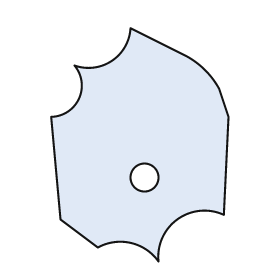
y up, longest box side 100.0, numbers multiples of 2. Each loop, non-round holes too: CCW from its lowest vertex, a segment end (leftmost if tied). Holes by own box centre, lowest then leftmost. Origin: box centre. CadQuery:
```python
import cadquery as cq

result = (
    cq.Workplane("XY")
    .moveTo(8.0, -50.0)
    .threePointArc((16.0, -32.0), (36.0, -30.0))
    .lineTo(38.0, 12.0)
    .lineTo(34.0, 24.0)
    .threePointArc((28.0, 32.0), (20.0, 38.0))
    .lineTo(-4.0, 50.0)
    .threePointArc((-12.0, 36.0), (-28.0, 34.0))
    .threePointArc((-26.0, 20.0), (-38.0, 12.0))
    .lineTo(-34.0, -32.0)
    .lineTo(-18.0, -44.0)
    .threePointArc((-4.0, -42.0), (8.0, -50.0))
    .close()
    .moveTo(2.0, -14.0)
    .circle(6.0)
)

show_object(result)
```